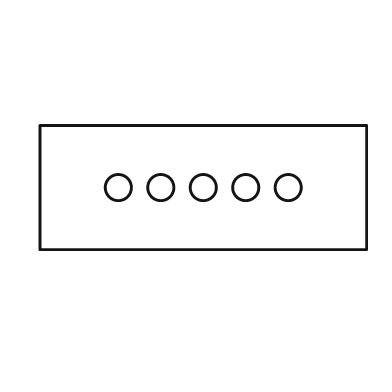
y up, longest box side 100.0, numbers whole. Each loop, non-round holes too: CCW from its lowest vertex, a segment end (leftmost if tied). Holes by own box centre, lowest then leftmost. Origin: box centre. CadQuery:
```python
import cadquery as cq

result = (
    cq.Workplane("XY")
    .moveTo(-50.0, -19.0)
    .lineTo(50.0, -19.0)
    .lineTo(50.0, 19.0)
    .lineTo(-50.0, 19.0)
    .close()
    .moveTo(-26.0, 0.0)
    .circle(4.0)
    .moveTo(-13.0, 0.0)
    .circle(4.0)
    .moveTo(0.0, 0.0)
    .circle(4.0)
    .moveTo(13.0, 0.0)
    .circle(4.0)
    .moveTo(26.0, 0.0)
    .circle(4.0)
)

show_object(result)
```